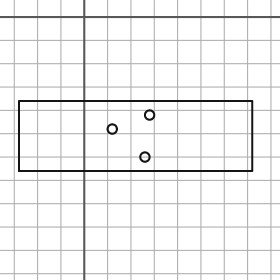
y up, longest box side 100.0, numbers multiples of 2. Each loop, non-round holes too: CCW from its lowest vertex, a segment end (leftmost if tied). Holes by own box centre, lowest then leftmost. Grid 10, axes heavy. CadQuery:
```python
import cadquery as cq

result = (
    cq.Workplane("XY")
    .moveTo(-28.0, -66.0)
    .lineTo(72.0, -66.0)
    .lineTo(72.0, -36.0)
    .lineTo(-28.0, -36.0)
    .close()
    .moveTo(26.0, -60.0)
    .circle(2.0)
    .moveTo(12.0, -48.0)
    .circle(2.0)
    .moveTo(28.0, -42.0)
    .circle(2.0)
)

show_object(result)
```